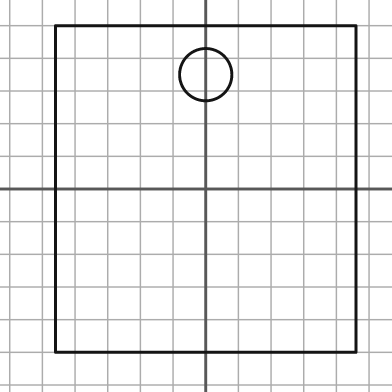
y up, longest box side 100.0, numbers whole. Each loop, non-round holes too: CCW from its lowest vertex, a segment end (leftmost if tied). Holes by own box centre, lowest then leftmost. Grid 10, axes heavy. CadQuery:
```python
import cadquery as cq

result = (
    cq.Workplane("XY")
    .moveTo(-46.0, -50.0)
    .lineTo(46.0, -50.0)
    .lineTo(46.0, 50.0)
    .lineTo(-46.0, 50.0)
    .close()
    .moveTo(0.0, 35.0)
    .circle(8.0)
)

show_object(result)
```